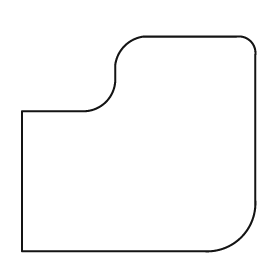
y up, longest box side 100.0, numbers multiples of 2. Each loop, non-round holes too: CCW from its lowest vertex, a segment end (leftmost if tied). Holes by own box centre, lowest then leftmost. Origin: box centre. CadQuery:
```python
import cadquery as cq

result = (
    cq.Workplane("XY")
    .moveTo(-50.0, -46.0)
    .lineTo(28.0, -46.0)
    .threePointArc((44.0, -40.0), (50.0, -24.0))
    .lineTo(50.0, 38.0)
    .threePointArc((48.0, 44.0), (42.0, 46.0))
    .lineTo(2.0, 46.0)
    .threePointArc((-6.0, 42.0), (-10.0, 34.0))
    .lineTo(-10.0, 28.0)
    .threePointArc((-14.0, 18.0), (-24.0, 14.0))
    .lineTo(-50.0, 14.0)
    .close()
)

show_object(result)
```